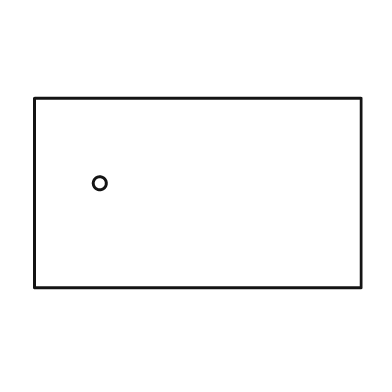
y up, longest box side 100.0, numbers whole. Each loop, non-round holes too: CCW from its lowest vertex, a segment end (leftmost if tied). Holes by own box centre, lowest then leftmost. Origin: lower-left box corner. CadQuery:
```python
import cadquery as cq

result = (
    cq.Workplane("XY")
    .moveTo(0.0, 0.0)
    .lineTo(100.0, 0.0)
    .lineTo(100.0, 58.0)
    .lineTo(0.0, 58.0)
    .close()
    .moveTo(20.0, 32.0)
    .circle(2.0)
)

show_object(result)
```